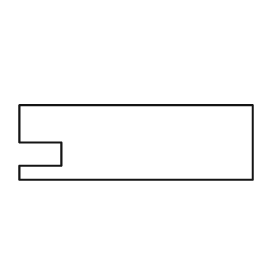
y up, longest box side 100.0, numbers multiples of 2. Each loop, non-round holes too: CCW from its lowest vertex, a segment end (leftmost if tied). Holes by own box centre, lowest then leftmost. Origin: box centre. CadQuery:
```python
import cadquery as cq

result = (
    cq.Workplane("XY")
    .moveTo(-50.0, -16.0)
    .lineTo(50.0, -16.0)
    .lineTo(50.0, 16.0)
    .lineTo(-50.0, 16.0)
    .lineTo(-50.0, 0.0)
    .lineTo(-32.0, 0.0)
    .lineTo(-32.0, -10.0)
    .lineTo(-50.0, -10.0)
    .close()
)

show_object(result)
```